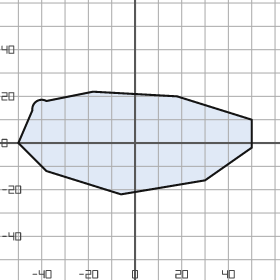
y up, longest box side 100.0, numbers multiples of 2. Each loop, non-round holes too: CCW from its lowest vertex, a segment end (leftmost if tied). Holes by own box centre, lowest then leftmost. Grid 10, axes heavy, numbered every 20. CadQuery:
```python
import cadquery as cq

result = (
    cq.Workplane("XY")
    .moveTo(-6.0, -22.0)
    .lineTo(30.0, -16.0)
    .lineTo(50.0, -2.0)
    .lineTo(50.0, 10.0)
    .lineTo(18.0, 20.0)
    .lineTo(-18.0, 22.0)
    .lineTo(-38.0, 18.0)
    .threePointArc((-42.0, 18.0), (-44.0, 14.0))
    .lineTo(-50.0, 0.0)
    .lineTo(-38.0, -12.0)
    .close()
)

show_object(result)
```